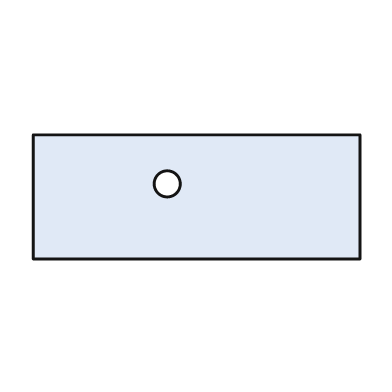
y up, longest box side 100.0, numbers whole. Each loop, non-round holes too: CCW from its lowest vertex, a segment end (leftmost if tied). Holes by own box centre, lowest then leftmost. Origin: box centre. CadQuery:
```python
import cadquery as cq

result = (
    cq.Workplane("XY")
    .moveTo(-50.0, -19.0)
    .lineTo(50.0, -19.0)
    .lineTo(50.0, 19.0)
    .lineTo(-50.0, 19.0)
    .close()
    .moveTo(-9.0, 4.0)
    .circle(4.0)
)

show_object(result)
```